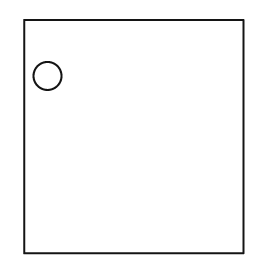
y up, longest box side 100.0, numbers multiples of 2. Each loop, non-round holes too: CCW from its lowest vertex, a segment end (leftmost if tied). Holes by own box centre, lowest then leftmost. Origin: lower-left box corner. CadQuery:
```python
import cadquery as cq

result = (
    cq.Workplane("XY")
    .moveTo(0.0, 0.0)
    .lineTo(94.0, 0.0)
    .lineTo(94.0, 100.0)
    .lineTo(0.0, 100.0)
    .close()
    .moveTo(10.0, 76.0)
    .circle(6.0)
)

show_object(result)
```